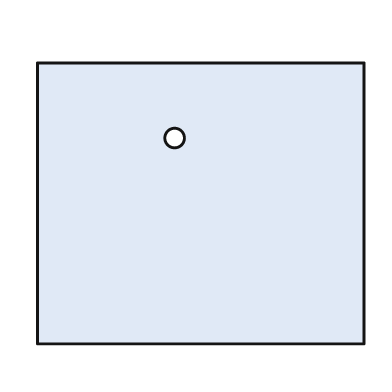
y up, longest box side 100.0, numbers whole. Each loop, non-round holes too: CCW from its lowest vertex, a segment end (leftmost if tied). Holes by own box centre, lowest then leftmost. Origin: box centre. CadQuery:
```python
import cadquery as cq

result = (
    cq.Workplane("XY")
    .moveTo(-50.0, -43.0)
    .lineTo(50.0, -43.0)
    .lineTo(50.0, 43.0)
    .lineTo(-50.0, 43.0)
    .close()
    .moveTo(-8.0, 20.0)
    .circle(3.0)
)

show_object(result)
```